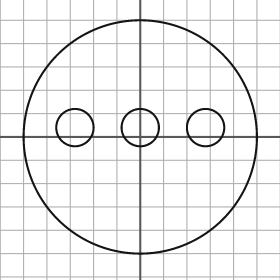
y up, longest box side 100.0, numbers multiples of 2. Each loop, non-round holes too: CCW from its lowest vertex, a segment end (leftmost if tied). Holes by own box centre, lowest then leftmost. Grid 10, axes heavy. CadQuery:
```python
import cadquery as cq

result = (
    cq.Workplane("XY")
    .moveTo(0.0, 0.0)
    .circle(50.0)
    .moveTo(-28.0, 4.0)
    .circle(8.0)
    .moveTo(0.0, 4.0)
    .circle(8.0)
    .moveTo(28.0, 4.0)
    .circle(8.0)
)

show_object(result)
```